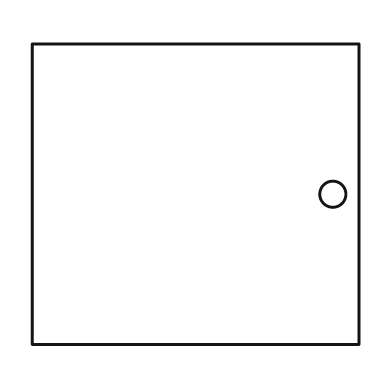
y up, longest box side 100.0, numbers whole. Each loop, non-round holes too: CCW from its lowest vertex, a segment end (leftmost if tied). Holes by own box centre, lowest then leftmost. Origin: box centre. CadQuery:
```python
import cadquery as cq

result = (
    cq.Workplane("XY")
    .moveTo(-50.0, -46.0)
    .lineTo(50.0, -46.0)
    .lineTo(50.0, 46.0)
    .lineTo(-50.0, 46.0)
    .close()
    .moveTo(42.0, 0.0)
    .circle(4.0)
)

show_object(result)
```